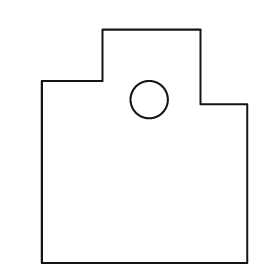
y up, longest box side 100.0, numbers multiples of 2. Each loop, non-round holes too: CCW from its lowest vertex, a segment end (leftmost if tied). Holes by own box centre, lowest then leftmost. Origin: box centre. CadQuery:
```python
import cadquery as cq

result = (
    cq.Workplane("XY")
    .moveTo(-44.0, -50.0)
    .lineTo(44.0, -50.0)
    .lineTo(44.0, 18.0)
    .lineTo(24.0, 18.0)
    .lineTo(24.0, 50.0)
    .lineTo(-18.0, 50.0)
    .lineTo(-18.0, 28.0)
    .lineTo(-44.0, 28.0)
    .close()
    .moveTo(2.0, 20.0)
    .circle(8.0)
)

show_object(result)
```